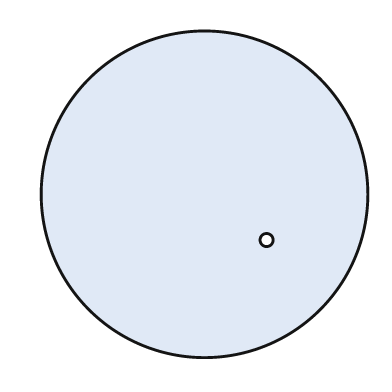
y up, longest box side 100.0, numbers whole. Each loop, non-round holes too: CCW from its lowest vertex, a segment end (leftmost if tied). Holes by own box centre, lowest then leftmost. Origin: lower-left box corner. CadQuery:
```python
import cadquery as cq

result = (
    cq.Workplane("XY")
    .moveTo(50.0, 50.0)
    .circle(50.0)
    .moveTo(69.0, 36.0)
    .circle(2.0)
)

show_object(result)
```